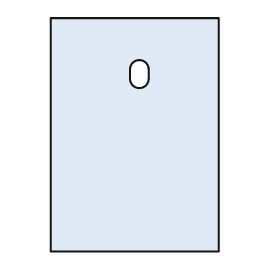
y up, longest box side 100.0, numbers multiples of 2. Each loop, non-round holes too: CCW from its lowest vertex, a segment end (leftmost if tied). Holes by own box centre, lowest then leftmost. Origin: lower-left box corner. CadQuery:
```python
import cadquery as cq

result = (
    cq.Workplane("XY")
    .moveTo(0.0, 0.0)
    .lineTo(72.0, 0.0)
    .lineTo(72.0, 100.0)
    .lineTo(0.0, 100.0)
    .close()
    .moveTo(34.0, 74.0)
    .threePointArc((38.0, 70.0), (42.0, 74.0))
    .lineTo(42.0, 78.0)
    .threePointArc((38.0, 82.0), (34.0, 78.0))
    .close()
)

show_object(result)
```